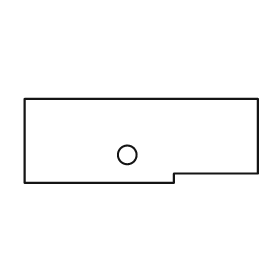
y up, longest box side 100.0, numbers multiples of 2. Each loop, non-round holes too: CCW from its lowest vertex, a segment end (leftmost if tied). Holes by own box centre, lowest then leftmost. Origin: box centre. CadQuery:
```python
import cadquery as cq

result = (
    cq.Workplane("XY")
    .moveTo(-50.0, -18.0)
    .lineTo(14.0, -18.0)
    .lineTo(14.0, -14.0)
    .lineTo(50.0, -14.0)
    .lineTo(50.0, 18.0)
    .lineTo(-50.0, 18.0)
    .close()
    .moveTo(-6.0, -6.0)
    .circle(4.0)
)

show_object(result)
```